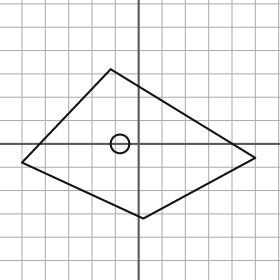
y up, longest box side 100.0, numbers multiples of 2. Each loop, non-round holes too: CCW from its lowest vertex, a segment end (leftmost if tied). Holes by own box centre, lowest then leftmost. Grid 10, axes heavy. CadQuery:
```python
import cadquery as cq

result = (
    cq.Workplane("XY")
    .moveTo(2.0, -32.0)
    .lineTo(50.0, -6.0)
    .lineTo(-12.0, 32.0)
    .lineTo(-50.0, -8.0)
    .close()
    .moveTo(-8.0, 0.0)
    .circle(4.0)
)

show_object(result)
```